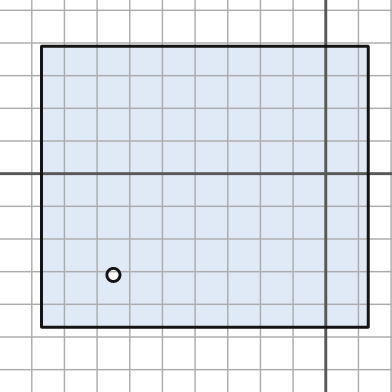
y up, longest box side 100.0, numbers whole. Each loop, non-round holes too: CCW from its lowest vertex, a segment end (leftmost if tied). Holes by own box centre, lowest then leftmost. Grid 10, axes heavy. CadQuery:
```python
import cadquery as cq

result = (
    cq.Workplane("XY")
    .moveTo(-87.0, -47.0)
    .lineTo(13.0, -47.0)
    .lineTo(13.0, 39.0)
    .lineTo(-87.0, 39.0)
    .close()
    .moveTo(-65.0, -31.0)
    .circle(2.0)
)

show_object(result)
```